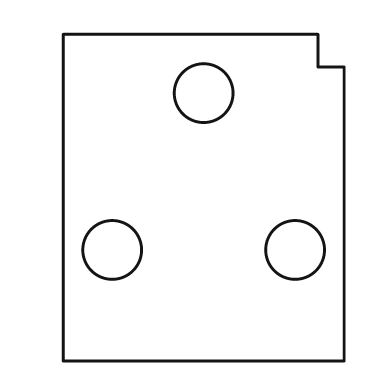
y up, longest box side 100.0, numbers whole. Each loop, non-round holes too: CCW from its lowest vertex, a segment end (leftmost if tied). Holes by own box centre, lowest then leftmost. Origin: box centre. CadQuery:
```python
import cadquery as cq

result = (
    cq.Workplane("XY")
    .moveTo(-43.0, -50.0)
    .lineTo(43.0, -50.0)
    .lineTo(43.0, 40.0)
    .lineTo(35.0, 40.0)
    .lineTo(35.0, 50.0)
    .lineTo(-43.0, 50.0)
    .close()
    .moveTo(-28.0, -16.0)
    .circle(9.0)
    .moveTo(28.0, -16.0)
    .circle(9.0)
    .moveTo(0.0, 32.0)
    .circle(9.0)
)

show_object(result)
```